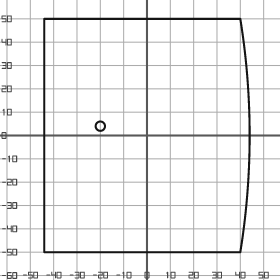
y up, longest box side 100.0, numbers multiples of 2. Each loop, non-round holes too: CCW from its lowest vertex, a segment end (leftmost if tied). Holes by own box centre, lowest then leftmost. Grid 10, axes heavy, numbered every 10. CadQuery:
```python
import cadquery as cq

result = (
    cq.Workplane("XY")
    .moveTo(-44.0, -50.0)
    .lineTo(40.0, -50.0)
    .threePointArc((44.0, 0.0), (40.0, 50.0))
    .lineTo(-44.0, 50.0)
    .close()
    .moveTo(-20.0, 4.0)
    .circle(2.0)
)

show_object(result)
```